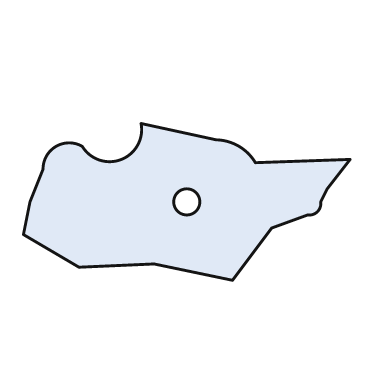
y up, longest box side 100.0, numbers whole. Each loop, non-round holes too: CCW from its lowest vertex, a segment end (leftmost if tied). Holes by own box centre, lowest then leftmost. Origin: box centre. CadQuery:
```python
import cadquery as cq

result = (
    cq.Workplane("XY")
    .moveTo(14.0, -24.0)
    .lineTo(26.0, -8.0)
    .lineTo(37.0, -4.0)
    .threePointArc((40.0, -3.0), (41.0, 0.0))
    .lineTo(43.0, 4.0)
    .lineTo(50.0, 13.0)
    .lineTo(21.0, 12.0)
    .threePointArc((16.0, 17.0), (9.0, 19.0))
    .lineTo(-14.0, 24.0)
    .threePointArc((-20.0, 13.0), (-32.0, 17.0))
    .threePointArc((-40.0, 17.0), (-44.0, 10.0))
    .lineTo(-48.0, 0.0)
    .lineTo(-50.0, -10.0)
    .lineTo(-33.0, -20.0)
    .lineTo(-10.0, -19.0)
    .close()
    .moveTo(0.0, 0.0)
    .circle(4.0)
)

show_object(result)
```